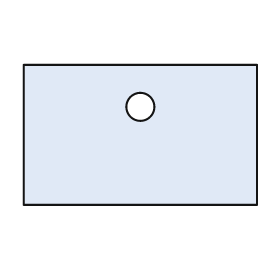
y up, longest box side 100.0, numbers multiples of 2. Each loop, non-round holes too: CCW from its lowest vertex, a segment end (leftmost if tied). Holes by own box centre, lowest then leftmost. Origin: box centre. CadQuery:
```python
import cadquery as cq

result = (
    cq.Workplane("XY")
    .moveTo(-50.0, -30.0)
    .lineTo(50.0, -30.0)
    .lineTo(50.0, 30.0)
    .lineTo(-50.0, 30.0)
    .close()
    .moveTo(0.0, 12.0)
    .circle(6.0)
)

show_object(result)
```